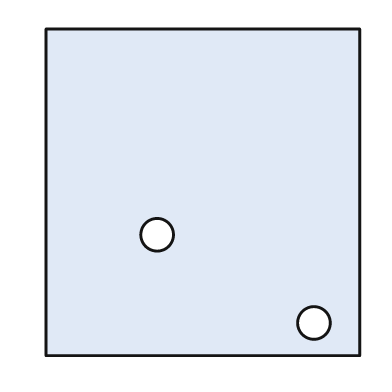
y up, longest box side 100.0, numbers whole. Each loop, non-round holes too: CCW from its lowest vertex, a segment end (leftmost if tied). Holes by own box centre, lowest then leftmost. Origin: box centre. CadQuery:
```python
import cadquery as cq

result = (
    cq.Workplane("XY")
    .moveTo(-48.0, -50.0)
    .lineTo(48.0, -50.0)
    .lineTo(48.0, 50.0)
    .lineTo(-48.0, 50.0)
    .close()
    .moveTo(34.0, -40.0)
    .circle(5.0)
    .moveTo(-14.0, -13.0)
    .circle(5.0)
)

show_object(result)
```